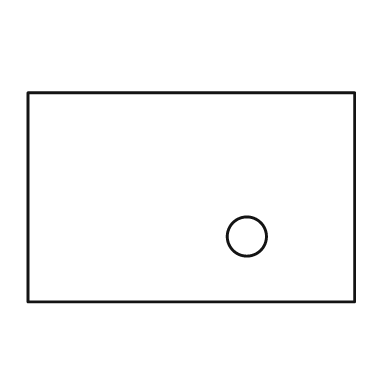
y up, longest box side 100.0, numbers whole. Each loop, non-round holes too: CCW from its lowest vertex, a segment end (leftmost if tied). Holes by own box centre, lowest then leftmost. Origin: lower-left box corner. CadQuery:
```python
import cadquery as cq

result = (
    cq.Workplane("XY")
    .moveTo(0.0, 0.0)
    .lineTo(100.0, 0.0)
    .lineTo(100.0, 64.0)
    .lineTo(0.0, 64.0)
    .close()
    .moveTo(67.0, 20.0)
    .circle(6.0)
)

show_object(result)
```